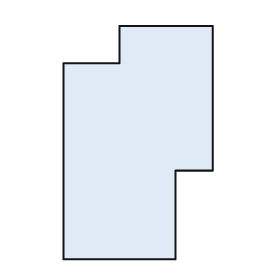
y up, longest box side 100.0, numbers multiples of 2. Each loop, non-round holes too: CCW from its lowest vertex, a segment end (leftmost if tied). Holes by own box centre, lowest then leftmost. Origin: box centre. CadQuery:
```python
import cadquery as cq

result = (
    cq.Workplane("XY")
    .moveTo(-32.0, -50.0)
    .lineTo(16.0, -50.0)
    .lineTo(16.0, -12.0)
    .lineTo(32.0, -12.0)
    .lineTo(32.0, 50.0)
    .lineTo(-8.0, 50.0)
    .lineTo(-8.0, 34.0)
    .lineTo(-32.0, 34.0)
    .close()
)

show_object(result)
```